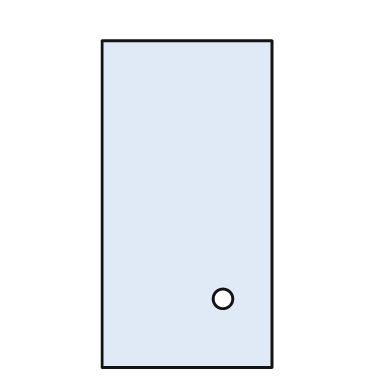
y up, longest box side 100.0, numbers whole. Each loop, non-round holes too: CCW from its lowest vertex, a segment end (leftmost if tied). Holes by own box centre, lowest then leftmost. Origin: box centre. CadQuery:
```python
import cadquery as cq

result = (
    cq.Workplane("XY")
    .moveTo(-26.0, -50.0)
    .lineTo(26.0, -50.0)
    .lineTo(26.0, 50.0)
    .lineTo(-26.0, 50.0)
    .close()
    .moveTo(11.0, -29.0)
    .circle(3.0)
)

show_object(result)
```